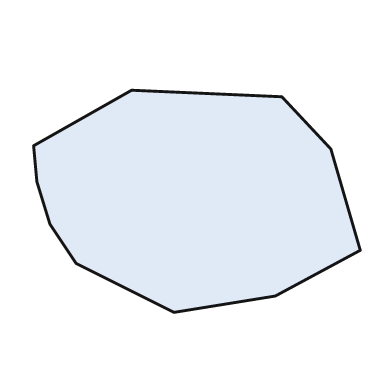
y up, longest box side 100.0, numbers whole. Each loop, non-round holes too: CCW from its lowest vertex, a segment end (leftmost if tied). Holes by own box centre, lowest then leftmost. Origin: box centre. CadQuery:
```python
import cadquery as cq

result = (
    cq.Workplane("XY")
    .moveTo(-7.0, -34.0)
    .lineTo(24.0, -29.0)
    .lineTo(50.0, -15.0)
    .lineTo(41.0, 16.0)
    .lineTo(26.0, 32.0)
    .lineTo(-20.0, 34.0)
    .lineTo(-50.0, 17.0)
    .lineTo(-49.0, 6.0)
    .lineTo(-45.0, -7.0)
    .lineTo(-37.0, -19.0)
    .close()
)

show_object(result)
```